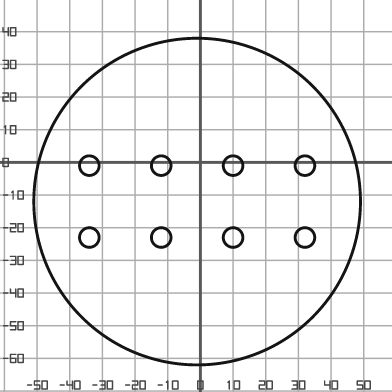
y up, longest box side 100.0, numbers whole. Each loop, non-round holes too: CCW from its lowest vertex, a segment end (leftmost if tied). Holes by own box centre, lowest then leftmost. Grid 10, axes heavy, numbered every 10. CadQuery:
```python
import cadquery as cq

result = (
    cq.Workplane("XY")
    .moveTo(-1.0, -12.0)
    .circle(50.0)
    .moveTo(-34.0, -23.0)
    .circle(3.0)
    .moveTo(-12.0, -23.0)
    .circle(3.0)
    .moveTo(10.0, -23.0)
    .circle(3.0)
    .moveTo(32.0, -23.0)
    .circle(3.0)
    .moveTo(-34.0, -1.0)
    .circle(3.0)
    .moveTo(-12.0, -1.0)
    .circle(3.0)
    .moveTo(10.0, -1.0)
    .circle(3.0)
    .moveTo(32.0, -1.0)
    .circle(3.0)
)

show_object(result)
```